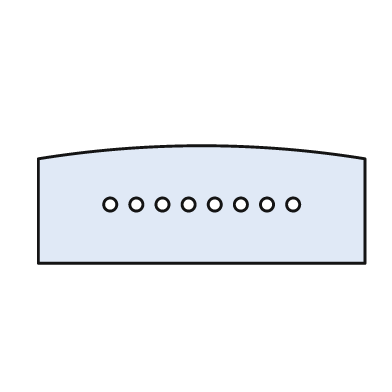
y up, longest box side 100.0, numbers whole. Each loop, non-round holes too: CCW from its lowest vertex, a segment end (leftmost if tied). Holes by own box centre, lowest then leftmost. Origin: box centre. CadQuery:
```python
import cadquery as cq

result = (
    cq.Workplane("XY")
    .moveTo(-50.0, -18.0)
    .lineTo(50.0, -18.0)
    .lineTo(50.0, 14.0)
    .threePointArc((0.0, 18.0), (-50.0, 14.0))
    .close()
    .moveTo(-28.0, 0.0)
    .circle(2.0)
    .moveTo(-20.0, 0.0)
    .circle(2.0)
    .moveTo(-12.0, 0.0)
    .circle(2.0)
    .moveTo(-4.0, 0.0)
    .circle(2.0)
    .moveTo(4.0, 0.0)
    .circle(2.0)
    .moveTo(12.0, 0.0)
    .circle(2.0)
    .moveTo(20.0, 0.0)
    .circle(2.0)
    .moveTo(28.0, 0.0)
    .circle(2.0)
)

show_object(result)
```